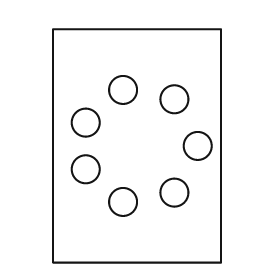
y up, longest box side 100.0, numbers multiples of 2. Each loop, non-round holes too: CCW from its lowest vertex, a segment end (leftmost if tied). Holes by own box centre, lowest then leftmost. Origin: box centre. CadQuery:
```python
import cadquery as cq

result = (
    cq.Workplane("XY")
    .moveTo(-36.0, -50.0)
    .lineTo(36.0, -50.0)
    .lineTo(36.0, 50.0)
    .lineTo(-36.0, 50.0)
    .close()
    .moveTo(-6.0, -24.0)
    .circle(6.0)
    .moveTo(16.0, -20.0)
    .circle(6.0)
    .moveTo(-22.0, -10.0)
    .circle(6.0)
    .moveTo(26.0, 0.0)
    .circle(6.0)
    .moveTo(-22.0, 10.0)
    .circle(6.0)
    .moveTo(16.0, 20.0)
    .circle(6.0)
    .moveTo(-6.0, 24.0)
    .circle(6.0)
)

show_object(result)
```